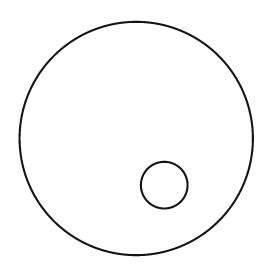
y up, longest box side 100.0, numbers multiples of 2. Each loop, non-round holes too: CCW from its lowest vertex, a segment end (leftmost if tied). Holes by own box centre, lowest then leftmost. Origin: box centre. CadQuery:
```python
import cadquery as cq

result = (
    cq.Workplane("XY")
    .moveTo(0.0, 0.0)
    .circle(50.0)
    .moveTo(12.0, -20.0)
    .circle(10.0)
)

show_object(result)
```